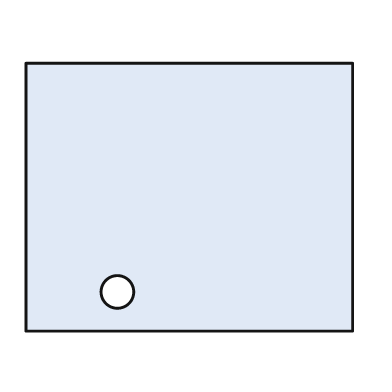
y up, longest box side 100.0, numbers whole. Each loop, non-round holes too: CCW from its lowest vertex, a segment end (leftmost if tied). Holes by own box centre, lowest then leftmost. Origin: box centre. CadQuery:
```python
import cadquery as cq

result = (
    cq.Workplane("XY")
    .moveTo(-50.0, -41.0)
    .lineTo(50.0, -41.0)
    .lineTo(50.0, 41.0)
    .lineTo(-50.0, 41.0)
    .close()
    .moveTo(-22.0, -29.0)
    .circle(5.0)
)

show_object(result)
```